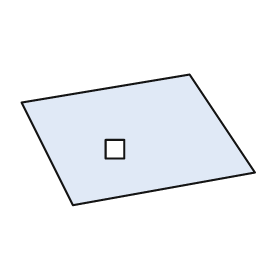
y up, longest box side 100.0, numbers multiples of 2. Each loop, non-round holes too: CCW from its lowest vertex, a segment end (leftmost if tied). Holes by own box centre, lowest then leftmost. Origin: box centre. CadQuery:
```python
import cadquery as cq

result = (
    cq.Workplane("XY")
    .moveTo(-28.0, -28.0)
    .lineTo(50.0, -14.0)
    .lineTo(22.0, 28.0)
    .lineTo(-50.0, 16.0)
    .close()
    .moveTo(-14.0, -8.0)
    .lineTo(-6.0, -8.0)
    .lineTo(-6.0, 0.0)
    .lineTo(-14.0, 0.0)
    .close()
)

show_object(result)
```